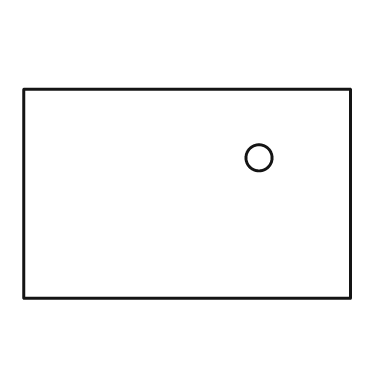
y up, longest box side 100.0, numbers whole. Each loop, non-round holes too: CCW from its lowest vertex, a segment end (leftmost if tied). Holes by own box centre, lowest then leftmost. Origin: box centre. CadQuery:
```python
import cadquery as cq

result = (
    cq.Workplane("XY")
    .moveTo(-50.0, -32.0)
    .lineTo(50.0, -32.0)
    .lineTo(50.0, 32.0)
    .lineTo(-50.0, 32.0)
    .close()
    .moveTo(22.0, 11.0)
    .circle(4.0)
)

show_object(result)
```